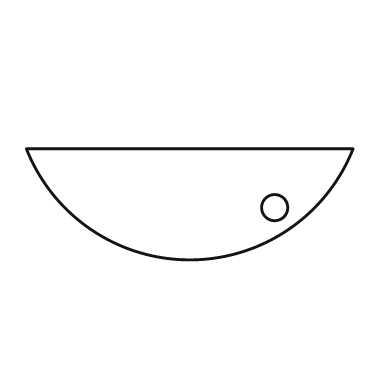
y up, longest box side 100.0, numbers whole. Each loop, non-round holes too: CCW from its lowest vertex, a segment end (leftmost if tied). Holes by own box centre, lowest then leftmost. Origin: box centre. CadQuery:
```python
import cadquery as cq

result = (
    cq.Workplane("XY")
    .moveTo(-50.0, 17.0)
    .threePointArc((0.0, -17.0), (50.0, 17.0))
    .close()
    .moveTo(26.0, -1.0)
    .circle(4.0)
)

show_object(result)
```